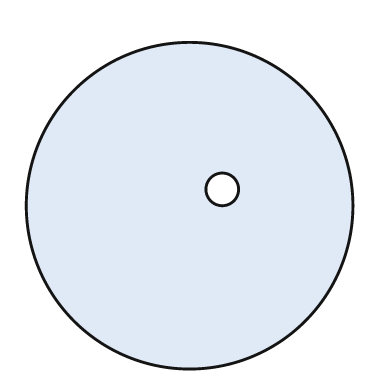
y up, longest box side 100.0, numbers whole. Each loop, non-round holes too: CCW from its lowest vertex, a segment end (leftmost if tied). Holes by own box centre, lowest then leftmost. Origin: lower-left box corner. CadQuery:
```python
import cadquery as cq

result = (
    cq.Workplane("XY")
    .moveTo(50.0, 50.0)
    .circle(50.0)
    .moveTo(60.0, 55.0)
    .circle(5.0)
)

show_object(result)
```